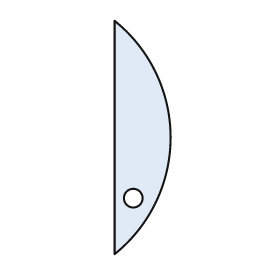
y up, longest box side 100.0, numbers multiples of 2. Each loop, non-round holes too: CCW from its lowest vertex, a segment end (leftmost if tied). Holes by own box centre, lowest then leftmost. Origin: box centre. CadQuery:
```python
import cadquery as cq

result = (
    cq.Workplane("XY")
    .moveTo(-12.0, -50.0)
    .threePointArc((12.0, 0.0), (-12.0, 50.0))
    .close()
    .moveTo(-4.0, -26.0)
    .circle(4.0)
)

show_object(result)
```